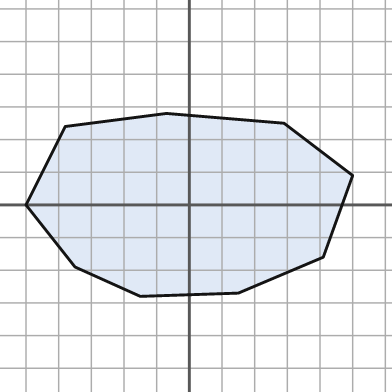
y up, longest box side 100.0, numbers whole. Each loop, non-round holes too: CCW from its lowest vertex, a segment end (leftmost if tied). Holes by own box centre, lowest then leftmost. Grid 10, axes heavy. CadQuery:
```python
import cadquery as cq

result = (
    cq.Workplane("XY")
    .moveTo(-15.0, -28.0)
    .lineTo(15.0, -27.0)
    .lineTo(41.0, -16.0)
    .lineTo(50.0, 9.0)
    .lineTo(29.0, 25.0)
    .lineTo(-7.0, 28.0)
    .lineTo(-38.0, 24.0)
    .lineTo(-50.0, 0.0)
    .lineTo(-35.0, -19.0)
    .close()
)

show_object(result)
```